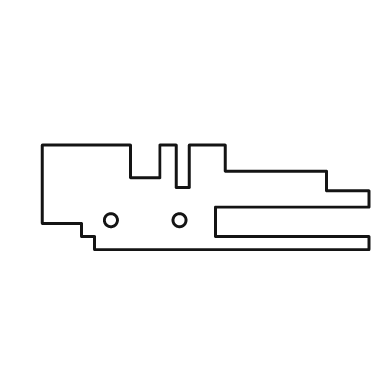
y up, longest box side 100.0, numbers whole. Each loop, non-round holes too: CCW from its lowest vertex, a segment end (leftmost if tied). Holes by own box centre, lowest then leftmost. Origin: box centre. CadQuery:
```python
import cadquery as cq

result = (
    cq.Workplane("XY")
    .moveTo(-34.0, -16.0)
    .lineTo(50.0, -16.0)
    .lineTo(50.0, -12.0)
    .lineTo(3.0, -12.0)
    .lineTo(3.0, -3.0)
    .lineTo(50.0, -3.0)
    .lineTo(50.0, 2.0)
    .lineTo(37.0, 2.0)
    .lineTo(37.0, 8.0)
    .lineTo(6.0, 8.0)
    .lineTo(6.0, 16.0)
    .lineTo(-5.0, 16.0)
    .lineTo(-5.0, 3.0)
    .lineTo(-9.0, 3.0)
    .lineTo(-9.0, 16.0)
    .lineTo(-14.0, 16.0)
    .lineTo(-14.0, 6.0)
    .lineTo(-23.0, 6.0)
    .lineTo(-23.0, 16.0)
    .lineTo(-50.0, 16.0)
    .lineTo(-50.0, -8.0)
    .lineTo(-38.0, -8.0)
    .lineTo(-38.0, -12.0)
    .lineTo(-34.0, -12.0)
    .close()
    .moveTo(-29.0, -7.0)
    .circle(2.0)
    .moveTo(-8.0, -7.0)
    .circle(2.0)
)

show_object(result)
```